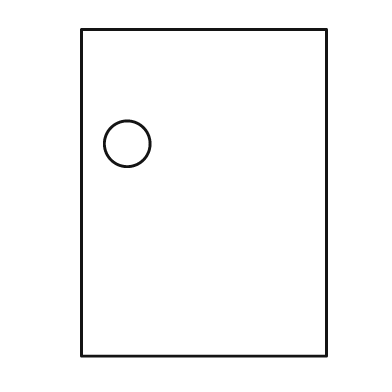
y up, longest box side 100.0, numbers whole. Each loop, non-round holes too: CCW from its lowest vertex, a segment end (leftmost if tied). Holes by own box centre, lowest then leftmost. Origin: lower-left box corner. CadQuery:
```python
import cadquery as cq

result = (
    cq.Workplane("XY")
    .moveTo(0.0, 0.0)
    .lineTo(75.0, 0.0)
    .lineTo(75.0, 100.0)
    .lineTo(0.0, 100.0)
    .close()
    .moveTo(14.0, 65.0)
    .circle(7.0)
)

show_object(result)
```